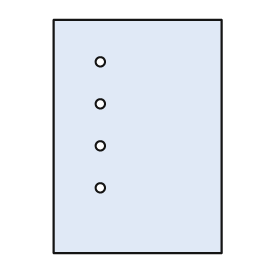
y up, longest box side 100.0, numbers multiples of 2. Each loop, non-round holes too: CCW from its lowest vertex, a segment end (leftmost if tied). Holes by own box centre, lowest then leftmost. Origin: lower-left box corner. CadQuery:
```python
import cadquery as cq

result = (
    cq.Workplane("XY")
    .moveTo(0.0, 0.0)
    .lineTo(72.0, 0.0)
    .lineTo(72.0, 100.0)
    .lineTo(0.0, 100.0)
    .close()
    .moveTo(20.0, 28.0)
    .circle(2.0)
    .moveTo(20.0, 46.0)
    .circle(2.0)
    .moveTo(20.0, 64.0)
    .circle(2.0)
    .moveTo(20.0, 82.0)
    .circle(2.0)
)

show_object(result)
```